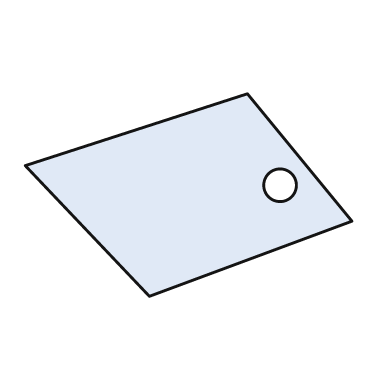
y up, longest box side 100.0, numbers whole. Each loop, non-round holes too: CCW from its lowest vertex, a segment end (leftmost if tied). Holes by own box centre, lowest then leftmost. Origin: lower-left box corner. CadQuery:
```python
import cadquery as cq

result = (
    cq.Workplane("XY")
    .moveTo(38.0, 0.0)
    .lineTo(100.0, 23.0)
    .lineTo(68.0, 62.0)
    .lineTo(0.0, 40.0)
    .close()
    .moveTo(78.0, 34.0)
    .circle(5.0)
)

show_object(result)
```